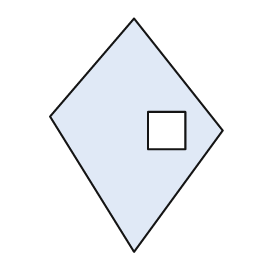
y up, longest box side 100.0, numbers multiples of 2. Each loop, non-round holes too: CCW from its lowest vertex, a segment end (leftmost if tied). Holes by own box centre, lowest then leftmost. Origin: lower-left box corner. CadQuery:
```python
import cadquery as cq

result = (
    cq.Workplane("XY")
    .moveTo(36.0, 0.0)
    .lineTo(74.0, 52.0)
    .lineTo(36.0, 100.0)
    .lineTo(0.0, 58.0)
    .close()
    .moveTo(42.0, 44.0)
    .lineTo(58.0, 44.0)
    .lineTo(58.0, 60.0)
    .lineTo(42.0, 60.0)
    .close()
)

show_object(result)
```